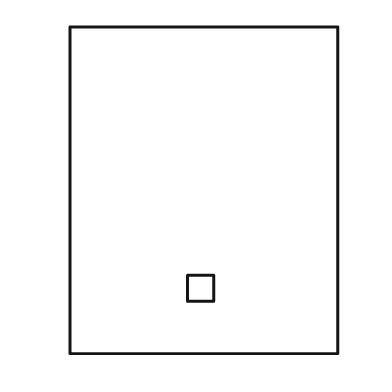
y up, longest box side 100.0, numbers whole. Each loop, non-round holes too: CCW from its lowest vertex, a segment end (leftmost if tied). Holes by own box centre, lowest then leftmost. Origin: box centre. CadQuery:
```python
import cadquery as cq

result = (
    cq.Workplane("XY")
    .moveTo(-41.0, -50.0)
    .lineTo(41.0, -50.0)
    .lineTo(41.0, 50.0)
    .lineTo(-41.0, 50.0)
    .close()
    .moveTo(-5.0, -34.0)
    .lineTo(3.0, -34.0)
    .lineTo(3.0, -26.0)
    .lineTo(-5.0, -26.0)
    .close()
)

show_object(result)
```